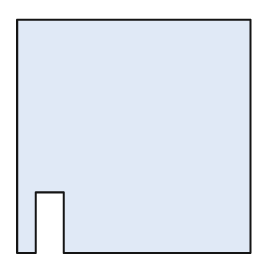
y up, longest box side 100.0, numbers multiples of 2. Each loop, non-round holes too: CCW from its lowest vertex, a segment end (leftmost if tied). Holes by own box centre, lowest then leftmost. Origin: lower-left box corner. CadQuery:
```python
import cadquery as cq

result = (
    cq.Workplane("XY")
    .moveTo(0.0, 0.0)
    .lineTo(8.0, 0.0)
    .lineTo(8.0, 26.0)
    .lineTo(20.0, 26.0)
    .lineTo(20.0, 0.0)
    .lineTo(100.0, 0.0)
    .lineTo(100.0, 100.0)
    .lineTo(0.0, 100.0)
    .close()
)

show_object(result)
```